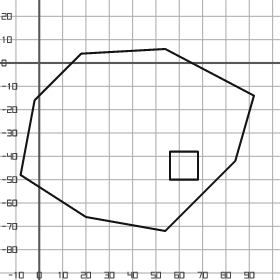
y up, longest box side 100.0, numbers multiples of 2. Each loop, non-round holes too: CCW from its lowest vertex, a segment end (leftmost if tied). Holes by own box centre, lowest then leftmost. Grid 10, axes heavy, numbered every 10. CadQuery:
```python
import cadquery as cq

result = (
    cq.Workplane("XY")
    .moveTo(54.0, -72.0)
    .lineTo(84.0, -42.0)
    .lineTo(92.0, -14.0)
    .lineTo(54.0, 6.0)
    .lineTo(18.0, 4.0)
    .lineTo(-2.0, -16.0)
    .lineTo(-8.0, -48.0)
    .lineTo(20.0, -66.0)
    .close()
    .moveTo(56.0, -50.0)
    .lineTo(68.0, -50.0)
    .lineTo(68.0, -38.0)
    .lineTo(56.0, -38.0)
    .close()
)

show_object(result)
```